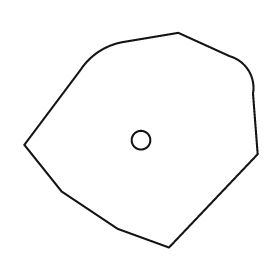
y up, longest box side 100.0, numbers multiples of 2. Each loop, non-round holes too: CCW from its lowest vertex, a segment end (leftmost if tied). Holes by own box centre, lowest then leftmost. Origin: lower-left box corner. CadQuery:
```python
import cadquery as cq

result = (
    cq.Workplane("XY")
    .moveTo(62.0, 0.0)
    .lineTo(100.0, 40.0)
    .lineTo(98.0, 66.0)
    .threePointArc((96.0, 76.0), (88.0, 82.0))
    .lineTo(66.0, 92.0)
    .lineTo(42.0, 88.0)
    .threePointArc((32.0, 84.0), (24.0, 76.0))
    .lineTo(0.0, 44.0)
    .lineTo(16.0, 24.0)
    .lineTo(40.0, 8.0)
    .close()
    .moveTo(50.0, 46.0)
    .circle(4.0)
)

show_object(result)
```